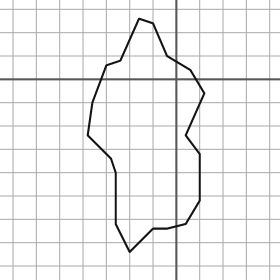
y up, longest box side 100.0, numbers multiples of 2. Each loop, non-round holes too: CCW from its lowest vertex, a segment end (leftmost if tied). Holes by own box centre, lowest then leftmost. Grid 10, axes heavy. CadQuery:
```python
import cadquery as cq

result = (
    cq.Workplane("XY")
    .moveTo(-20.0, -74.0)
    .lineTo(-10.0, -64.0)
    .lineTo(-4.0, -64.0)
    .lineTo(4.0, -62.0)
    .lineTo(10.0, -52.0)
    .lineTo(10.0, -32.0)
    .lineTo(4.0, -24.0)
    .lineTo(12.0, -6.0)
    .lineTo(6.0, 4.0)
    .lineTo(-4.0, 10.0)
    .lineTo(-10.0, 24.0)
    .lineTo(-16.0, 26.0)
    .lineTo(-24.0, 8.0)
    .lineTo(-30.0, 6.0)
    .lineTo(-36.0, -10.0)
    .lineTo(-38.0, -24.0)
    .lineTo(-28.0, -34.0)
    .lineTo(-26.0, -40.0)
    .lineTo(-26.0, -62.0)
    .close()
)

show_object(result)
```